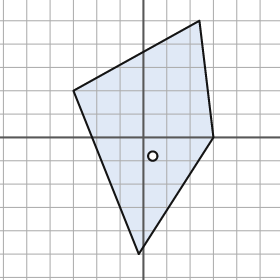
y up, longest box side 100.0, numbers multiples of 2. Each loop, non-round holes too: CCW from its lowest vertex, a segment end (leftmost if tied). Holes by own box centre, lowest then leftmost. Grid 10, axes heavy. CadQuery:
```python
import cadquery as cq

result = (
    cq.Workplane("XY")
    .moveTo(-2.0, -50.0)
    .lineTo(30.0, 0.0)
    .lineTo(24.0, 50.0)
    .lineTo(-30.0, 20.0)
    .close()
    .moveTo(4.0, -8.0)
    .circle(2.0)
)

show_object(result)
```